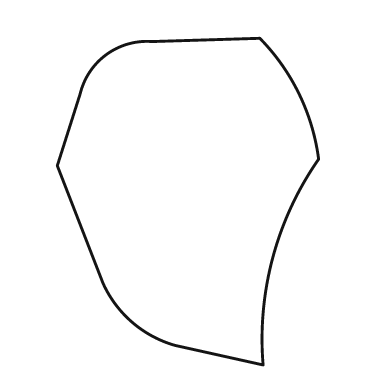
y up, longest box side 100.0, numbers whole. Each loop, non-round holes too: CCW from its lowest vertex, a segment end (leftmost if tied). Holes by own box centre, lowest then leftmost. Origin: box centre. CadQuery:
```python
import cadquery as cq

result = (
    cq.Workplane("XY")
    .moveTo(23.0, -50.0)
    .threePointArc((26.0, -17.0), (40.0, 13.0))
    .threePointArc((34.0, 33.0), (22.0, 50.0))
    .lineTo(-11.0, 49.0)
    .threePointArc((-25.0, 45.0), (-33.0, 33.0))
    .lineTo(-40.0, 11.0)
    .lineTo(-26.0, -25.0)
    .threePointArc((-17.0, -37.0), (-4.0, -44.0))
    .close()
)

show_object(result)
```